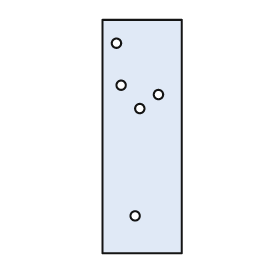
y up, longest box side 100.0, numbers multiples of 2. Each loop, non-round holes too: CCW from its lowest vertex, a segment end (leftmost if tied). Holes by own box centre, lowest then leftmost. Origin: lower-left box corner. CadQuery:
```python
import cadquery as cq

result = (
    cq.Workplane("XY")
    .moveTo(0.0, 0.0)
    .lineTo(34.0, 0.0)
    .lineTo(34.0, 100.0)
    .lineTo(0.0, 100.0)
    .close()
    .moveTo(14.0, 16.0)
    .circle(2.0)
    .moveTo(16.0, 62.0)
    .circle(2.0)
    .moveTo(24.0, 68.0)
    .circle(2.0)
    .moveTo(8.0, 72.0)
    .circle(2.0)
    .moveTo(6.0, 90.0)
    .circle(2.0)
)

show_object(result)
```